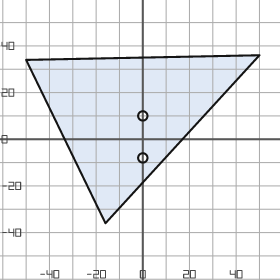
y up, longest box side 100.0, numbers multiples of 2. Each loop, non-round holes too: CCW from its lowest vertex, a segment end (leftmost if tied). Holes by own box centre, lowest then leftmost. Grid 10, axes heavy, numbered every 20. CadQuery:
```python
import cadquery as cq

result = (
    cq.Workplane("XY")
    .moveTo(-16.0, -36.0)
    .lineTo(50.0, 36.0)
    .lineTo(-50.0, 34.0)
    .close()
    .moveTo(0.0, -8.0)
    .circle(2.0)
    .moveTo(0.0, 10.0)
    .circle(2.0)
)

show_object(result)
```